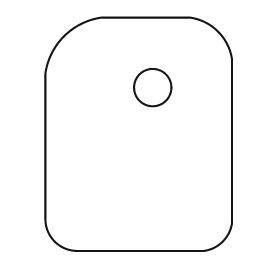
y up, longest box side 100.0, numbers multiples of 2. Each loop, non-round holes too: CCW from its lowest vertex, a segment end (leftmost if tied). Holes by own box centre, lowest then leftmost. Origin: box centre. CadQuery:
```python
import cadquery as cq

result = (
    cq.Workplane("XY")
    .moveTo(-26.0, -50.0)
    .lineTo(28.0, -50.0)
    .threePointArc((36.0, -46.0), (40.0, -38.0))
    .lineTo(40.0, 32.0)
    .threePointArc((34.0, 44.0), (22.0, 50.0))
    .lineTo(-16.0, 50.0)
    .threePointArc((-32.0, 42.0), (-40.0, 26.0))
    .lineTo(-40.0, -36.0)
    .threePointArc((-36.0, -46.0), (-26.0, -50.0))
    .close()
    .moveTo(6.0, 20.0)
    .circle(8.0)
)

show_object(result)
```